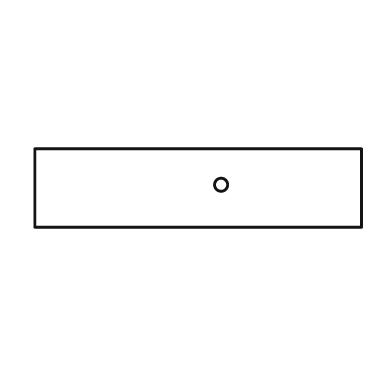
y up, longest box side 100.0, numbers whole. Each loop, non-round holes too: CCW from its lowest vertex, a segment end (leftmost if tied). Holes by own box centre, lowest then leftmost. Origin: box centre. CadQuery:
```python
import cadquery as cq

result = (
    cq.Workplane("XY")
    .moveTo(-50.0, -12.0)
    .lineTo(50.0, -12.0)
    .lineTo(50.0, 12.0)
    .lineTo(-50.0, 12.0)
    .close()
    .moveTo(7.0, 1.0)
    .circle(2.0)
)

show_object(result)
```